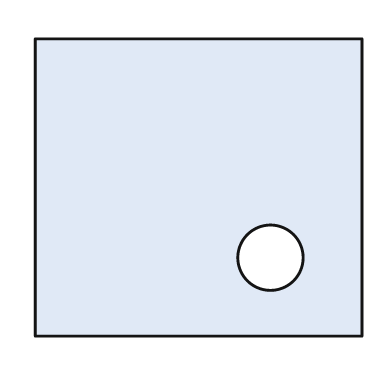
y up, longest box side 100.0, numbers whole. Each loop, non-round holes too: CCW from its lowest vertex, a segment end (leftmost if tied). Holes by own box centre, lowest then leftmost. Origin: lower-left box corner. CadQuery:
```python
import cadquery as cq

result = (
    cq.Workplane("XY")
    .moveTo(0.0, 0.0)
    .lineTo(100.0, 0.0)
    .lineTo(100.0, 91.0)
    .lineTo(0.0, 91.0)
    .close()
    .moveTo(72.0, 24.0)
    .circle(10.0)
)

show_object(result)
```